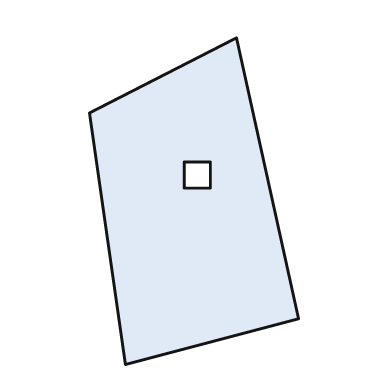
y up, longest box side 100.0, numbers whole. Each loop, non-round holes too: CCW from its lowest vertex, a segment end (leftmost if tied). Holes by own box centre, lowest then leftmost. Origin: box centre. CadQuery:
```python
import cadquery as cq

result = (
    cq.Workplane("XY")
    .moveTo(-21.0, -50.0)
    .lineTo(32.0, -36.0)
    .lineTo(13.0, 50.0)
    .lineTo(-32.0, 27.0)
    .close()
    .moveTo(-3.0, 4.0)
    .lineTo(5.0, 4.0)
    .lineTo(5.0, 12.0)
    .lineTo(-3.0, 12.0)
    .close()
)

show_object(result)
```